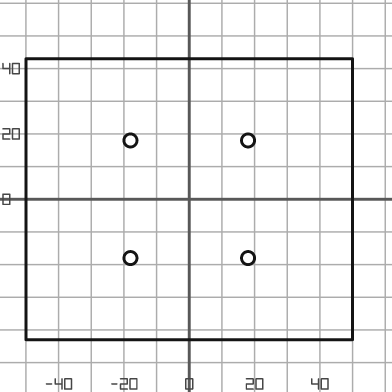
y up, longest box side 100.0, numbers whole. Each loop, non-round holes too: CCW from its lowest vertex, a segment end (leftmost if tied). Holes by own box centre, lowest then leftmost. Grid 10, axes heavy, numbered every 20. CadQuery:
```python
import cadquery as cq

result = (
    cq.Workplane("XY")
    .moveTo(-50.0, -43.0)
    .lineTo(50.0, -43.0)
    .lineTo(50.0, 43.0)
    .lineTo(-50.0, 43.0)
    .close()
    .moveTo(-18.0, -18.0)
    .circle(2.0)
    .moveTo(18.0, -18.0)
    .circle(2.0)
    .moveTo(-18.0, 18.0)
    .circle(2.0)
    .moveTo(18.0, 18.0)
    .circle(2.0)
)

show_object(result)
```